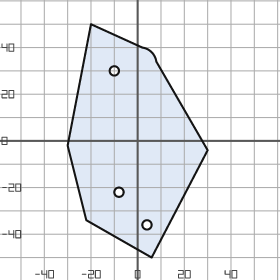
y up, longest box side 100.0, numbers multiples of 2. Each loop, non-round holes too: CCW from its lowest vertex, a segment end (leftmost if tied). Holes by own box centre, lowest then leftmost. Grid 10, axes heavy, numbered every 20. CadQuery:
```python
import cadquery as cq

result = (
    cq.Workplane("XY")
    .moveTo(6.0, -50.0)
    .lineTo(30.0, -4.0)
    .lineTo(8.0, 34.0)
    .threePointArc((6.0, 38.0), (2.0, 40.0))
    .lineTo(-20.0, 50.0)
    .lineTo(-30.0, -2.0)
    .lineTo(-22.0, -34.0)
    .close()
    .moveTo(4.0, -36.0)
    .circle(2.0)
    .moveTo(-8.0, -22.0)
    .circle(2.0)
    .moveTo(-10.0, 30.0)
    .circle(2.0)
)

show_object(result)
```